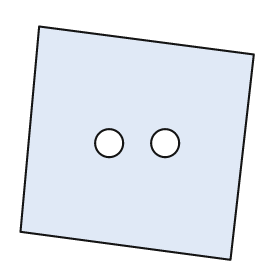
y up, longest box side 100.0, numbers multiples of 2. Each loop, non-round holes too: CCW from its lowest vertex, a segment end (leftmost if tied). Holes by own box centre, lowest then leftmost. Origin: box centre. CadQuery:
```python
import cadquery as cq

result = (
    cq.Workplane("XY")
    .moveTo(40.0, -50.0)
    .lineTo(50.0, 38.0)
    .lineTo(-42.0, 50.0)
    .lineTo(-50.0, -38.0)
    .close()
    .moveTo(-12.0, 0.0)
    .circle(6.0)
    .moveTo(12.0, 0.0)
    .circle(6.0)
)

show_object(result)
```